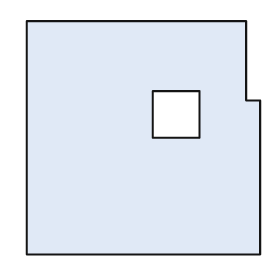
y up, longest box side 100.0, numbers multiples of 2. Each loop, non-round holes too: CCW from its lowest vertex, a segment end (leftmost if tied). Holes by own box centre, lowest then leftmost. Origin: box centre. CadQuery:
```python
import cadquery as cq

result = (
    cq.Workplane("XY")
    .moveTo(-50.0, -50.0)
    .lineTo(50.0, -50.0)
    .lineTo(50.0, 16.0)
    .lineTo(44.0, 16.0)
    .lineTo(44.0, 50.0)
    .lineTo(-50.0, 50.0)
    .close()
    .moveTo(4.0, 0.0)
    .lineTo(24.0, 0.0)
    .lineTo(24.0, 20.0)
    .lineTo(4.0, 20.0)
    .close()
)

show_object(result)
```